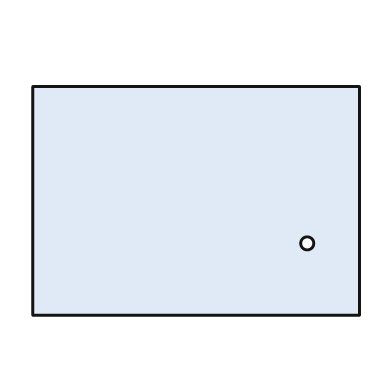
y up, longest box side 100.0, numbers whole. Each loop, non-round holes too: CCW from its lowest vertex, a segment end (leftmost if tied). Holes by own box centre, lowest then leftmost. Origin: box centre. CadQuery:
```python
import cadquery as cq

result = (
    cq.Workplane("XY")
    .moveTo(-50.0, -35.0)
    .lineTo(50.0, -35.0)
    .lineTo(50.0, 35.0)
    .lineTo(-50.0, 35.0)
    .close()
    .moveTo(34.0, -13.0)
    .circle(2.0)
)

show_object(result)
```